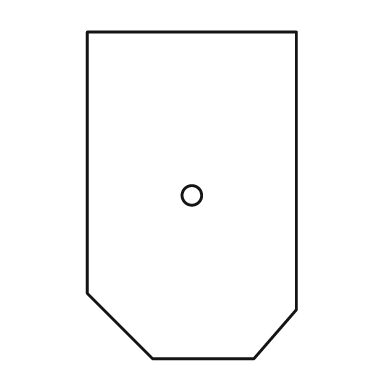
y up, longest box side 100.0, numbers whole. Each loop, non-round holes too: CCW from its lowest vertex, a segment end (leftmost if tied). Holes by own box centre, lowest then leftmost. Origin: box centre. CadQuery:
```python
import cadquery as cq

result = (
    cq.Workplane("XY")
    .moveTo(-12.0, -50.0)
    .lineTo(19.0, -50.0)
    .lineTo(32.0, -35.0)
    .lineTo(32.0, 50.0)
    .lineTo(-32.0, 50.0)
    .lineTo(-32.0, -30.0)
    .close()
    .moveTo(0.0, 0.0)
    .circle(3.0)
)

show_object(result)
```